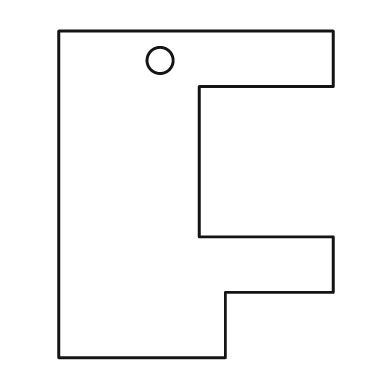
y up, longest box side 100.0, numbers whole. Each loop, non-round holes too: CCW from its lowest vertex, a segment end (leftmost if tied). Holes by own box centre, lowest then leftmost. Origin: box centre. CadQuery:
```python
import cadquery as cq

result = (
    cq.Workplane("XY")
    .moveTo(-42.0, -50.0)
    .lineTo(9.0, -50.0)
    .lineTo(9.0, -30.0)
    .lineTo(42.0, -30.0)
    .lineTo(42.0, -13.0)
    .lineTo(1.0, -13.0)
    .lineTo(1.0, 33.0)
    .lineTo(42.0, 33.0)
    .lineTo(42.0, 50.0)
    .lineTo(-42.0, 50.0)
    .close()
    .moveTo(-11.0, 41.0)
    .circle(4.0)
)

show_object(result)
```